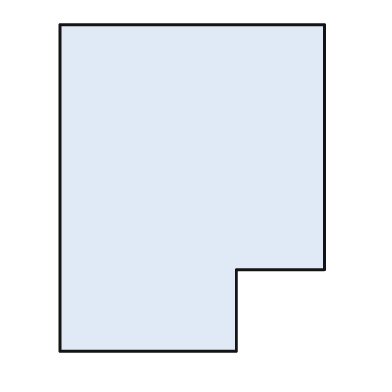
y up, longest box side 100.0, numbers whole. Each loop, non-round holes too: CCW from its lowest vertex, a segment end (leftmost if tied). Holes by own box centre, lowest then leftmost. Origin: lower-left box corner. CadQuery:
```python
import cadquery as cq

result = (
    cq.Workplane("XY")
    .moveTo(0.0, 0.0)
    .lineTo(54.0, 0.0)
    .lineTo(54.0, 25.0)
    .lineTo(81.0, 25.0)
    .lineTo(81.0, 100.0)
    .lineTo(0.0, 100.0)
    .close()
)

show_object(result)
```